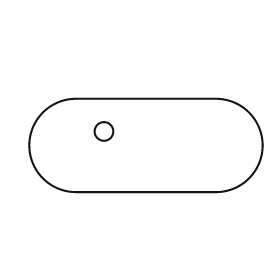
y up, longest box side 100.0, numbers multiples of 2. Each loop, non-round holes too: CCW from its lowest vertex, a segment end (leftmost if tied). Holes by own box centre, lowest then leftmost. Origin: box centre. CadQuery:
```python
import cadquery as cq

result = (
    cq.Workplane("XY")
    .moveTo(-30.0, -20.0)
    .lineTo(30.0, -20.0)
    .threePointArc((50.0, 0.0), (30.0, 20.0))
    .lineTo(-30.0, 20.0)
    .threePointArc((-50.0, 0.0), (-30.0, -20.0))
    .close()
    .moveTo(-18.0, 6.0)
    .circle(4.0)
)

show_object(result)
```